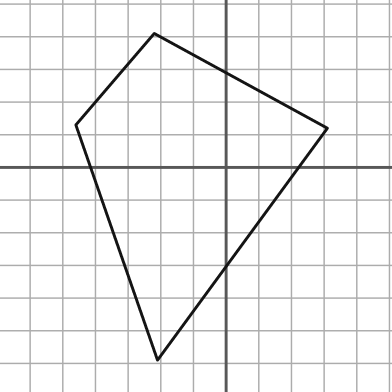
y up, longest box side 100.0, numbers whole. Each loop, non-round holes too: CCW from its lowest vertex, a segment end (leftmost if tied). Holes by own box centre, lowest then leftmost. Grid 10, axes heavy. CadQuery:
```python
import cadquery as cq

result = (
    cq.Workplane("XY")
    .moveTo(-21.0, -59.0)
    .lineTo(31.0, 12.0)
    .lineTo(-22.0, 41.0)
    .lineTo(-46.0, 13.0)
    .close()
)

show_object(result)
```